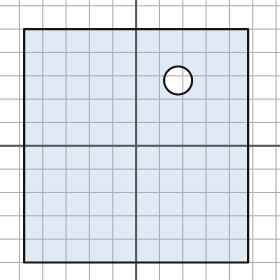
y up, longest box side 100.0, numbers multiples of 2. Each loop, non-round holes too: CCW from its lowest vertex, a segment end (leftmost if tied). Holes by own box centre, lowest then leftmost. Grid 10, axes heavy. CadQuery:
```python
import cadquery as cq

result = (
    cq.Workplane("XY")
    .moveTo(-48.0, -50.0)
    .lineTo(48.0, -50.0)
    .lineTo(48.0, 50.0)
    .lineTo(-48.0, 50.0)
    .close()
    .moveTo(18.0, 28.0)
    .circle(6.0)
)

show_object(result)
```